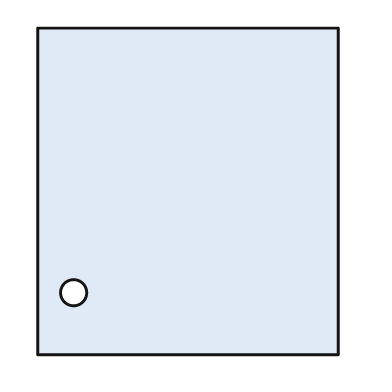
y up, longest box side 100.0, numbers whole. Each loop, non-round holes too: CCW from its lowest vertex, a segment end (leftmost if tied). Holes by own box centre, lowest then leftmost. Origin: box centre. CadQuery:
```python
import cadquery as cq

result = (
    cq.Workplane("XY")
    .moveTo(-46.0, -50.0)
    .lineTo(46.0, -50.0)
    .lineTo(46.0, 50.0)
    .lineTo(-46.0, 50.0)
    .close()
    .moveTo(-35.0, -31.0)
    .circle(4.0)
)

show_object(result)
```